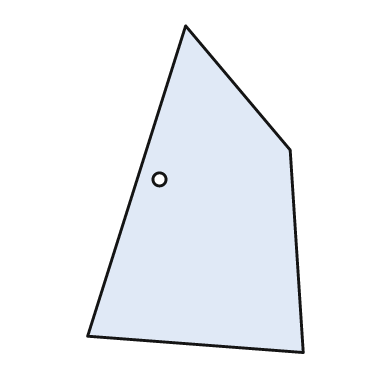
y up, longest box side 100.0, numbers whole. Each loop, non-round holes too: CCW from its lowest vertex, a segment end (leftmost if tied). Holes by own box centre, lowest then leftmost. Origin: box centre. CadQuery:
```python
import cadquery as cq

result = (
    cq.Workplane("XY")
    .moveTo(33.0, -50.0)
    .lineTo(29.0, 12.0)
    .lineTo(-3.0, 50.0)
    .lineTo(-33.0, -45.0)
    .close()
    .moveTo(-11.0, 3.0)
    .circle(2.0)
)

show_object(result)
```